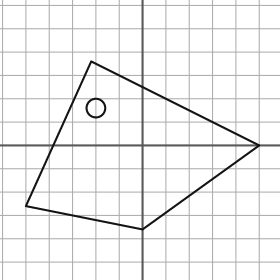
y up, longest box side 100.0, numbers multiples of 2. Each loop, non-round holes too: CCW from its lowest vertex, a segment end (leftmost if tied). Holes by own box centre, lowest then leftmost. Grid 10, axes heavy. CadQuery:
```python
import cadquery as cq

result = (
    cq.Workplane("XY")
    .moveTo(0.0, -36.0)
    .lineTo(50.0, 0.0)
    .lineTo(-22.0, 36.0)
    .lineTo(-50.0, -26.0)
    .close()
    .moveTo(-20.0, 16.0)
    .circle(4.0)
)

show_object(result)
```